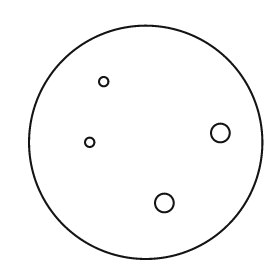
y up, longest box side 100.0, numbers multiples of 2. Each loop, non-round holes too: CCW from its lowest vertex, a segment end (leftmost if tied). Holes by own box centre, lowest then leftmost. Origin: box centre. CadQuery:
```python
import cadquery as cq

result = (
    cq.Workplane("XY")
    .moveTo(0.0, 0.0)
    .circle(50.0)
    .moveTo(8.0, -26.0)
    .circle(4.0)
    .moveTo(-24.0, 0.0)
    .circle(2.0)
    .moveTo(32.0, 4.0)
    .circle(4.0)
    .moveTo(-18.0, 26.0)
    .circle(2.0)
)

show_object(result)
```